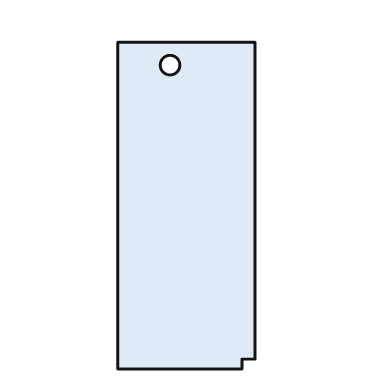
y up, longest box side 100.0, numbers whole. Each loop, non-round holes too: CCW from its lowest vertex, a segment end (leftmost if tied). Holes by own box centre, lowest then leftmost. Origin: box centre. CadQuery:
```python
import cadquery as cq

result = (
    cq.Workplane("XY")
    .moveTo(-21.0, -50.0)
    .lineTo(17.0, -50.0)
    .lineTo(17.0, -47.0)
    .lineTo(21.0, -47.0)
    .lineTo(21.0, 50.0)
    .lineTo(-21.0, 50.0)
    .close()
    .moveTo(-5.0, 43.0)
    .circle(3.0)
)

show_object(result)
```